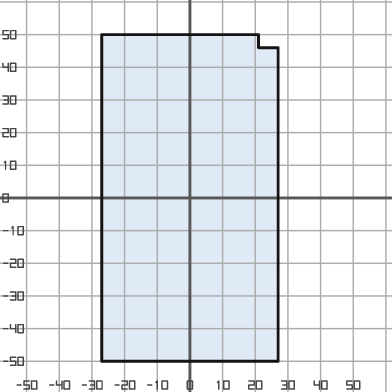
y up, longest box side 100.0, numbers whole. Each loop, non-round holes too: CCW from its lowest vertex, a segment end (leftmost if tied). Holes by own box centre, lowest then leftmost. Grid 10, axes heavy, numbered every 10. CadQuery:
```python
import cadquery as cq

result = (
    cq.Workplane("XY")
    .moveTo(-27.0, -50.0)
    .lineTo(27.0, -50.0)
    .lineTo(27.0, 46.0)
    .lineTo(21.0, 46.0)
    .lineTo(21.0, 50.0)
    .lineTo(-27.0, 50.0)
    .close()
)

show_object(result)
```